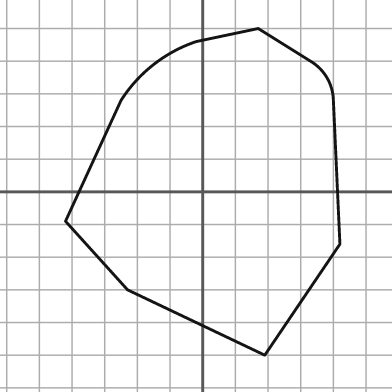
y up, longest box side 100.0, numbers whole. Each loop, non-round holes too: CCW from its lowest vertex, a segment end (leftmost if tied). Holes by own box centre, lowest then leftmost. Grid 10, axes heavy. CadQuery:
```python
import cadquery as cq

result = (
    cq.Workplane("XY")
    .moveTo(19.0, -50.0)
    .lineTo(42.0, -16.0)
    .lineTo(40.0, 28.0)
    .threePointArc((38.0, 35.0), (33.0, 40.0))
    .lineTo(17.0, 50.0)
    .lineTo(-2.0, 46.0)
    .threePointArc((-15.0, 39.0), (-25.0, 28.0))
    .lineTo(-42.0, -9.0)
    .lineTo(-23.0, -30.0)
    .close()
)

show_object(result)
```